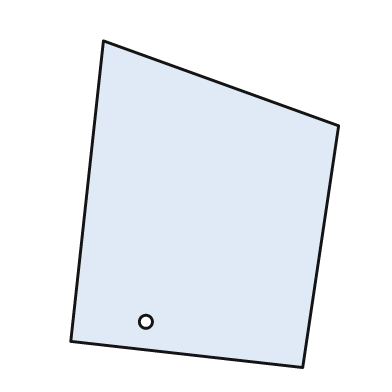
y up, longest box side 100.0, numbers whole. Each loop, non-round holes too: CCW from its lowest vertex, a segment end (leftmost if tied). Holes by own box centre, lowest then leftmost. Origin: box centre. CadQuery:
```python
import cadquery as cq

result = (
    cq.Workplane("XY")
    .moveTo(30.0, -50.0)
    .lineTo(41.0, 24.0)
    .lineTo(-31.0, 50.0)
    .lineTo(-41.0, -42.0)
    .close()
    .moveTo(-18.0, -36.0)
    .circle(2.0)
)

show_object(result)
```